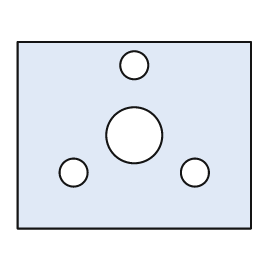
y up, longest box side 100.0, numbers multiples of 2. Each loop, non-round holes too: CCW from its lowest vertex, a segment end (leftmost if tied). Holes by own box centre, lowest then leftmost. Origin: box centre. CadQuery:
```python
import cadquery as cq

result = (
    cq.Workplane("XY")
    .moveTo(-50.0, -40.0)
    .lineTo(50.0, -40.0)
    .lineTo(50.0, 40.0)
    .lineTo(-50.0, 40.0)
    .close()
    .moveTo(-26.0, -16.0)
    .circle(6.0)
    .moveTo(26.0, -16.0)
    .circle(6.0)
    .moveTo(0.0, 0.0)
    .circle(12.0)
    .moveTo(0.0, 30.0)
    .circle(6.0)
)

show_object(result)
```